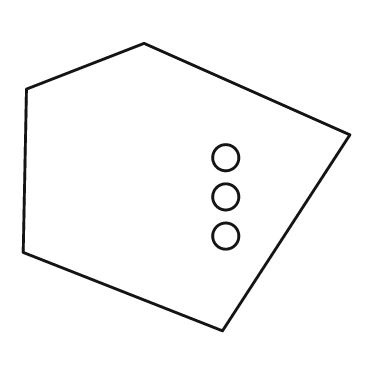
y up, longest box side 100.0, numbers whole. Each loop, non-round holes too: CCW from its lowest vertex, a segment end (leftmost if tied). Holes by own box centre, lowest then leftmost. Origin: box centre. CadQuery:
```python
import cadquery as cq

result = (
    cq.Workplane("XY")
    .moveTo(11.0, -44.0)
    .lineTo(50.0, 16.0)
    .lineTo(-13.0, 44.0)
    .lineTo(-49.0, 30.0)
    .lineTo(-50.0, -20.0)
    .close()
    .moveTo(12.0, -15.0)
    .circle(4.0)
    .moveTo(12.0, -3.0)
    .circle(4.0)
    .moveTo(12.0, 9.0)
    .circle(4.0)
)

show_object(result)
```